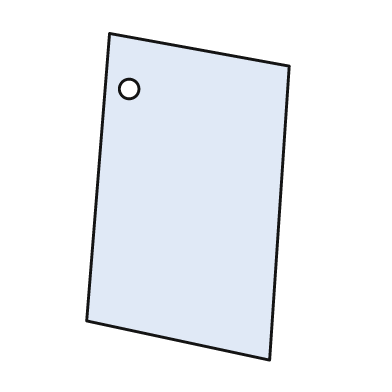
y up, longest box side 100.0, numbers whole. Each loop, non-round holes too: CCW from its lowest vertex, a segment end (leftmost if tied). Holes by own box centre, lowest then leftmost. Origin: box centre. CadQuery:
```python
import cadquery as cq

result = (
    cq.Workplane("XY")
    .moveTo(25.0, -50.0)
    .lineTo(31.0, 40.0)
    .lineTo(-24.0, 50.0)
    .lineTo(-31.0, -38.0)
    .close()
    .moveTo(-18.0, 33.0)
    .circle(3.0)
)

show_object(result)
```